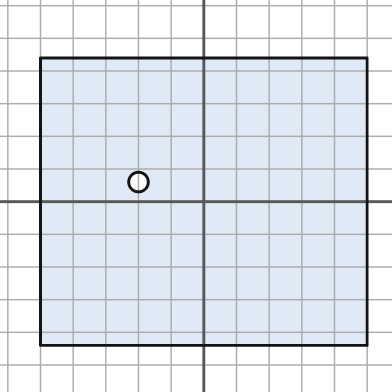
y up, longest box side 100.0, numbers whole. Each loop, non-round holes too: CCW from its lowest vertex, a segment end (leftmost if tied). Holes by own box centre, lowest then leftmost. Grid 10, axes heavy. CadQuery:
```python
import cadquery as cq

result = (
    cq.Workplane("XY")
    .moveTo(-50.0, -44.0)
    .lineTo(50.0, -44.0)
    .lineTo(50.0, 44.0)
    .lineTo(-50.0, 44.0)
    .close()
    .moveTo(-20.0, 6.0)
    .circle(3.0)
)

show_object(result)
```